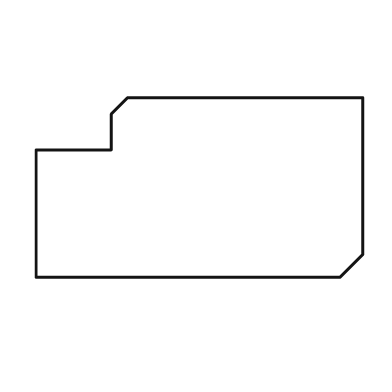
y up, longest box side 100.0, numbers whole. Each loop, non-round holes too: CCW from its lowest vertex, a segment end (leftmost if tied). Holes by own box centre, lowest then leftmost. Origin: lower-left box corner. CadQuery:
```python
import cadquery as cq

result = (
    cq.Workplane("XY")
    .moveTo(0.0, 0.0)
    .lineTo(93.0, 0.0)
    .lineTo(100.0, 7.0)
    .lineTo(100.0, 55.0)
    .lineTo(28.0, 55.0)
    .lineTo(23.0, 50.0)
    .lineTo(23.0, 39.0)
    .lineTo(0.0, 39.0)
    .close()
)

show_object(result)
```